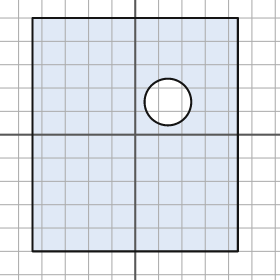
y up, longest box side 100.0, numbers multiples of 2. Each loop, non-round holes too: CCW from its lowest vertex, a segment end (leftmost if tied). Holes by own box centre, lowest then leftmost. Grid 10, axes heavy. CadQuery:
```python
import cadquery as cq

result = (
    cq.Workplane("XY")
    .moveTo(-44.0, -50.0)
    .lineTo(44.0, -50.0)
    .lineTo(44.0, 50.0)
    .lineTo(-44.0, 50.0)
    .close()
    .moveTo(14.0, 14.0)
    .circle(10.0)
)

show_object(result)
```